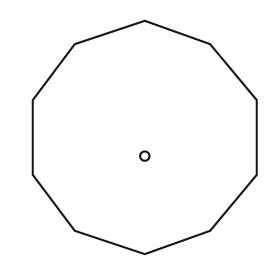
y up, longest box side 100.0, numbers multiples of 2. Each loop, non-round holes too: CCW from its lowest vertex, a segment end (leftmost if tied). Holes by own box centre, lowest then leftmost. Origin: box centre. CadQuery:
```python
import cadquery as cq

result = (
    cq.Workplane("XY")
    .moveTo(0.0, -50.0)
    .lineTo(28.0, -40.0)
    .lineTo(48.0, -16.0)
    .lineTo(48.0, 16.0)
    .lineTo(28.0, 40.0)
    .lineTo(0.0, 50.0)
    .lineTo(-30.0, 40.0)
    .lineTo(-48.0, 16.0)
    .lineTo(-48.0, -16.0)
    .lineTo(-30.0, -40.0)
    .close()
    .moveTo(0.0, -8.0)
    .circle(2.0)
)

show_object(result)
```